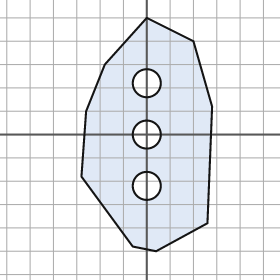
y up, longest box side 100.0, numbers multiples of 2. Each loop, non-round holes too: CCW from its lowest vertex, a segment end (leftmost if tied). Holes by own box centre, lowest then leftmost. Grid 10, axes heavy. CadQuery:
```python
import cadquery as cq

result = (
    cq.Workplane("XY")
    .moveTo(4.0, -50.0)
    .lineTo(26.0, -38.0)
    .lineTo(28.0, 12.0)
    .lineTo(20.0, 40.0)
    .lineTo(0.0, 50.0)
    .lineTo(-18.0, 30.0)
    .lineTo(-26.0, 10.0)
    .lineTo(-28.0, -18.0)
    .lineTo(-6.0, -48.0)
    .close()
    .moveTo(0.0, -22.0)
    .circle(6.0)
    .moveTo(0.0, 0.0)
    .circle(6.0)
    .moveTo(0.0, 22.0)
    .circle(6.0)
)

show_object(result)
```